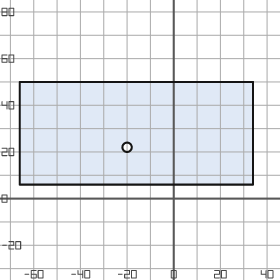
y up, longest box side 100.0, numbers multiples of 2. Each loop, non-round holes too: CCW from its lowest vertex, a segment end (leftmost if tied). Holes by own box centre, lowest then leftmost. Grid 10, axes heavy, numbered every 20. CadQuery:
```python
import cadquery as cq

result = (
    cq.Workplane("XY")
    .moveTo(-66.0, 6.0)
    .lineTo(34.0, 6.0)
    .lineTo(34.0, 50.0)
    .lineTo(-66.0, 50.0)
    .close()
    .moveTo(-20.0, 22.0)
    .circle(2.0)
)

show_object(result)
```